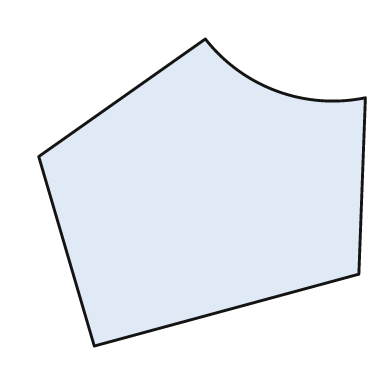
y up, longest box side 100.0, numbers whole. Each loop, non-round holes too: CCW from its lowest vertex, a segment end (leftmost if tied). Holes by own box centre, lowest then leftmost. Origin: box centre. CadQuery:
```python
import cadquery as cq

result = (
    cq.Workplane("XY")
    .moveTo(-33.0, -47.0)
    .lineTo(48.0, -25.0)
    .lineTo(50.0, 29.0)
    .threePointArc((23.0, 31.0), (1.0, 47.0))
    .lineTo(-50.0, 11.0)
    .close()
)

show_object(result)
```